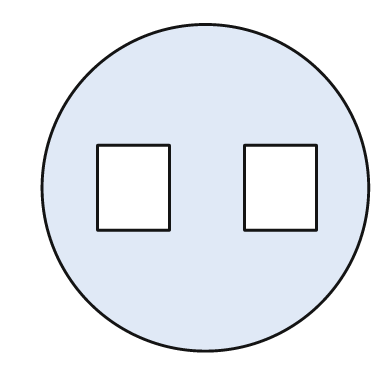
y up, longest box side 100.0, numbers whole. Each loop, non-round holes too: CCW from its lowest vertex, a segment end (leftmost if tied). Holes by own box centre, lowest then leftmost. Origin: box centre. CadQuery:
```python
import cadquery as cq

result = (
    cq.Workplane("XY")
    .moveTo(0.0, 0.0)
    .circle(50.0)
    .moveTo(-33.0, -13.0)
    .lineTo(-11.0, -13.0)
    .lineTo(-11.0, 13.0)
    .lineTo(-33.0, 13.0)
    .close()
    .moveTo(12.0, -13.0)
    .lineTo(34.0, -13.0)
    .lineTo(34.0, 13.0)
    .lineTo(12.0, 13.0)
    .close()
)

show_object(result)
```